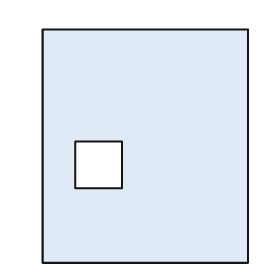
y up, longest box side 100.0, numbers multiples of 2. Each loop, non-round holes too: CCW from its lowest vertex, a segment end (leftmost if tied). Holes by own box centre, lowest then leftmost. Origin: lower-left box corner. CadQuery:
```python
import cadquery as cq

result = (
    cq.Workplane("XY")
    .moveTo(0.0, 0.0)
    .lineTo(88.0, 0.0)
    .lineTo(88.0, 100.0)
    .lineTo(0.0, 100.0)
    .close()
    .moveTo(14.0, 32.0)
    .lineTo(34.0, 32.0)
    .lineTo(34.0, 52.0)
    .lineTo(14.0, 52.0)
    .close()
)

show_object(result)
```